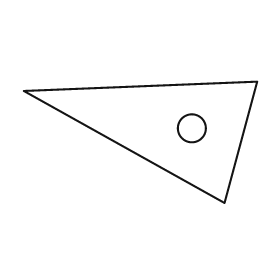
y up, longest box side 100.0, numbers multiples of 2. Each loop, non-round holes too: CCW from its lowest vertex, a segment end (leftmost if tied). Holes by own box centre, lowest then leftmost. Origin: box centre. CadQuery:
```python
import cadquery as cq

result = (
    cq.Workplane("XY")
    .moveTo(36.0, -26.0)
    .lineTo(50.0, 26.0)
    .lineTo(-50.0, 22.0)
    .close()
    .moveTo(22.0, 6.0)
    .circle(6.0)
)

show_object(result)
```